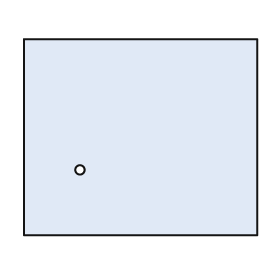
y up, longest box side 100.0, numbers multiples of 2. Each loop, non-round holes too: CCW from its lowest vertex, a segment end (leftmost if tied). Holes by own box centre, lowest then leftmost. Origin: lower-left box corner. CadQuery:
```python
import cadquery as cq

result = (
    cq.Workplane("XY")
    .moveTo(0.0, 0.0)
    .lineTo(100.0, 0.0)
    .lineTo(100.0, 84.0)
    .lineTo(0.0, 84.0)
    .close()
    .moveTo(24.0, 28.0)
    .circle(2.0)
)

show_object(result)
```